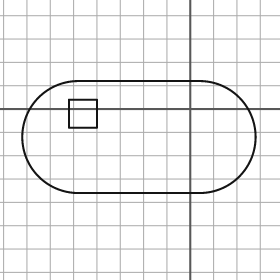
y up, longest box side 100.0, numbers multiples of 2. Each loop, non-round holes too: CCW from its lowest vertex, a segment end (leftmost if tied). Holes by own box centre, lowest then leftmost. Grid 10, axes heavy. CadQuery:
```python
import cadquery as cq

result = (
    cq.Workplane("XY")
    .moveTo(-48.0, -36.0)
    .lineTo(4.0, -36.0)
    .threePointArc((28.0, -12.0), (4.0, 12.0))
    .lineTo(-48.0, 12.0)
    .threePointArc((-72.0, -12.0), (-48.0, -36.0))
    .close()
    .moveTo(-52.0, -8.0)
    .lineTo(-40.0, -8.0)
    .lineTo(-40.0, 4.0)
    .lineTo(-52.0, 4.0)
    .close()
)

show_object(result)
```